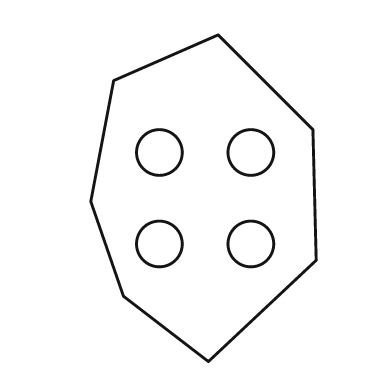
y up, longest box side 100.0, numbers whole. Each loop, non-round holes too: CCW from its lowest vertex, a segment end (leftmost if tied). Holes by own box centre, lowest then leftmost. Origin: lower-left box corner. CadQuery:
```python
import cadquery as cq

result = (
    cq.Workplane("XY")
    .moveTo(36.0, 0.0)
    .lineTo(69.0, 31.0)
    .lineTo(68.0, 71.0)
    .lineTo(39.0, 100.0)
    .lineTo(7.0, 86.0)
    .lineTo(0.0, 49.0)
    .lineTo(10.0, 20.0)
    .close()
    .moveTo(21.0, 36.0)
    .circle(7.0)
    .moveTo(49.0, 36.0)
    .circle(7.0)
    .moveTo(21.0, 64.0)
    .circle(7.0)
    .moveTo(49.0, 64.0)
    .circle(7.0)
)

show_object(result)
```